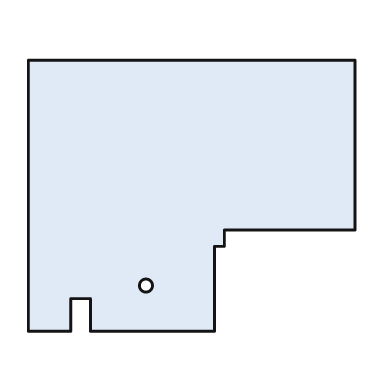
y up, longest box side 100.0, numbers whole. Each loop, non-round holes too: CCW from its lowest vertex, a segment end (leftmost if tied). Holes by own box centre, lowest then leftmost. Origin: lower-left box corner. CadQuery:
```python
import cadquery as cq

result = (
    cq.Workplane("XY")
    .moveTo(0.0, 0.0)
    .lineTo(13.0, 0.0)
    .lineTo(13.0, 10.0)
    .lineTo(19.0, 10.0)
    .lineTo(19.0, 0.0)
    .lineTo(57.0, 0.0)
    .lineTo(57.0, 26.0)
    .lineTo(60.0, 26.0)
    .lineTo(60.0, 31.0)
    .lineTo(100.0, 31.0)
    .lineTo(100.0, 83.0)
    .lineTo(0.0, 83.0)
    .close()
    .moveTo(36.0, 14.0)
    .circle(2.0)
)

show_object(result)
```